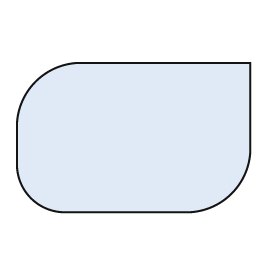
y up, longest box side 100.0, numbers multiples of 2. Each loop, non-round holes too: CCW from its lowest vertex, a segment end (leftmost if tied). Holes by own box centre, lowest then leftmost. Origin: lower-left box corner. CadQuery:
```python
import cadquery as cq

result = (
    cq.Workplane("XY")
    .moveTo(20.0, 0.0)
    .lineTo(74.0, 0.0)
    .threePointArc((92.0, 8.0), (100.0, 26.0))
    .lineTo(100.0, 64.0)
    .lineTo(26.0, 64.0)
    .threePointArc((8.0, 56.0), (0.0, 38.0))
    .lineTo(0.0, 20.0)
    .threePointArc((6.0, 6.0), (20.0, 0.0))
    .close()
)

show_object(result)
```